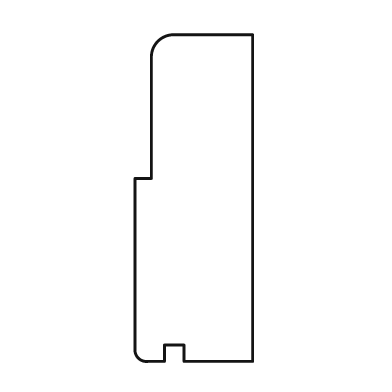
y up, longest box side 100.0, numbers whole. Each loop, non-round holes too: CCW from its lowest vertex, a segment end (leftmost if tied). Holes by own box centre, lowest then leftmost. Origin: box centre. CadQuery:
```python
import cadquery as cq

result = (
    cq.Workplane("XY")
    .moveTo(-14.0, -50.0)
    .lineTo(-9.0, -50.0)
    .lineTo(-9.0, -45.0)
    .lineTo(-3.0, -45.0)
    .lineTo(-3.0, -50.0)
    .lineTo(18.0, -50.0)
    .lineTo(18.0, 50.0)
    .lineTo(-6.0, 50.0)
    .threePointArc((-11.0, 48.0), (-13.0, 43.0))
    .lineTo(-13.0, 6.0)
    .lineTo(-18.0, 6.0)
    .lineTo(-18.0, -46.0)
    .threePointArc((-17.0, -49.0), (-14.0, -50.0))
    .close()
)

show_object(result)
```